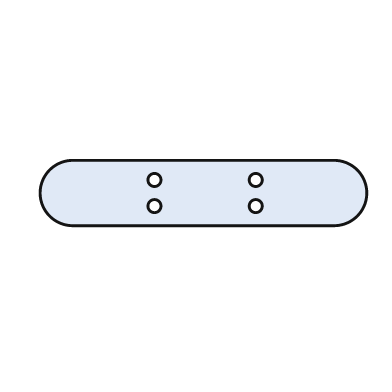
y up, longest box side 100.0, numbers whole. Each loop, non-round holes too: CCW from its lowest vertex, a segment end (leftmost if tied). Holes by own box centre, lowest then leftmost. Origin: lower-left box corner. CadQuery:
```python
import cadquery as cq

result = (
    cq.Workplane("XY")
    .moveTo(10.0, 0.0)
    .lineTo(90.0, 0.0)
    .threePointArc((100.0, 10.0), (90.0, 20.0))
    .lineTo(10.0, 20.0)
    .threePointArc((0.0, 10.0), (10.0, 0.0))
    .close()
    .moveTo(35.0, 6.0)
    .circle(2.0)
    .moveTo(66.0, 6.0)
    .circle(2.0)
    .moveTo(35.0, 14.0)
    .circle(2.0)
    .moveTo(66.0, 14.0)
    .circle(2.0)
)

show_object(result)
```